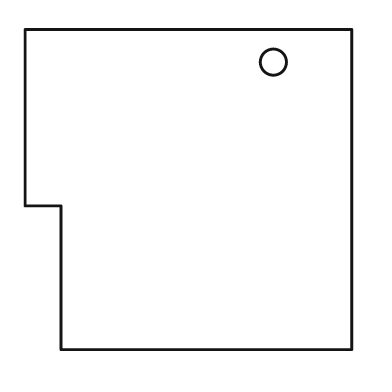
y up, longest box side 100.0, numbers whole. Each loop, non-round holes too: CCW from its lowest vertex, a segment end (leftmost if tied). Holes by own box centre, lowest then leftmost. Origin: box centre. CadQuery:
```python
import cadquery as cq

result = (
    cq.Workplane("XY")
    .moveTo(-39.0, -49.0)
    .lineTo(50.0, -49.0)
    .lineTo(50.0, 49.0)
    .lineTo(-50.0, 49.0)
    .lineTo(-50.0, -5.0)
    .lineTo(-39.0, -5.0)
    .close()
    .moveTo(26.0, 39.0)
    .circle(4.0)
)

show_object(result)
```